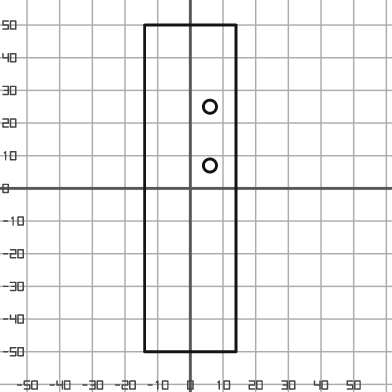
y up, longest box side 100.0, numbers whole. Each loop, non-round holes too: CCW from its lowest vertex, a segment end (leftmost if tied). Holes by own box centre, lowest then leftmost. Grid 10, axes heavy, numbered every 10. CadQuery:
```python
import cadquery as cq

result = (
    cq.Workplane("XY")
    .moveTo(-14.0, -50.0)
    .lineTo(14.0, -50.0)
    .lineTo(14.0, 50.0)
    .lineTo(-14.0, 50.0)
    .close()
    .moveTo(6.0, 7.0)
    .circle(2.0)
    .moveTo(6.0, 25.0)
    .circle(2.0)
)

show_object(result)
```